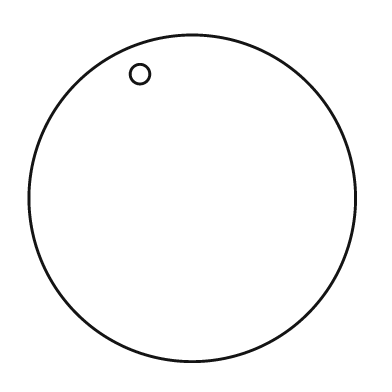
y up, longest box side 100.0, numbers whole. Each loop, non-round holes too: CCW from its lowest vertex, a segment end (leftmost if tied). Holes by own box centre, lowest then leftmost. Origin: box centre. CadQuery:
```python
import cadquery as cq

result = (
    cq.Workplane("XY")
    .moveTo(0.0, 0.0)
    .circle(50.0)
    .moveTo(-16.0, 38.0)
    .circle(3.0)
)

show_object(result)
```